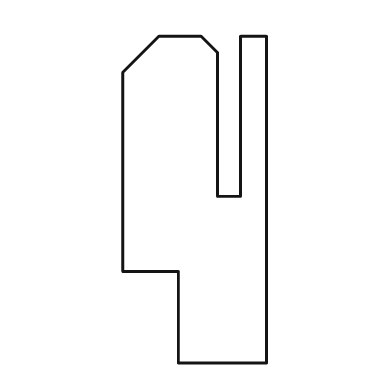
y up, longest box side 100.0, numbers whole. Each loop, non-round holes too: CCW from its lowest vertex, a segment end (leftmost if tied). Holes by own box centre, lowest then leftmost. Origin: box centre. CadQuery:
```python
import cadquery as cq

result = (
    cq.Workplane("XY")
    .moveTo(-5.0, -50.0)
    .lineTo(22.0, -50.0)
    .lineTo(22.0, 50.0)
    .lineTo(14.0, 50.0)
    .lineTo(14.0, 1.0)
    .lineTo(7.0, 1.0)
    .lineTo(7.0, 45.0)
    .lineTo(2.0, 50.0)
    .lineTo(-11.0, 50.0)
    .lineTo(-22.0, 39.0)
    .lineTo(-22.0, -22.0)
    .lineTo(-5.0, -22.0)
    .close()
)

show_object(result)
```